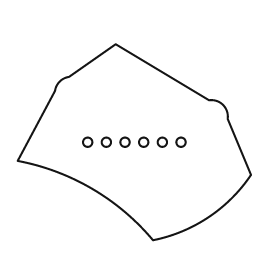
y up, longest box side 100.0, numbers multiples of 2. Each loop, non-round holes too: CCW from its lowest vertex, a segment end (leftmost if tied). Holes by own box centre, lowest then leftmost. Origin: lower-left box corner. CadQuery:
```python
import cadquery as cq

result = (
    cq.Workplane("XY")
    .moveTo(58.0, 0.0)
    .threePointArc((82.0, 10.0), (100.0, 28.0))
    .lineTo(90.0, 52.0)
    .threePointArc((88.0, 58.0), (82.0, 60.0))
    .lineTo(42.0, 84.0)
    .lineTo(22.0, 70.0)
    .threePointArc((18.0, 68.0), (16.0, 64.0))
    .lineTo(0.0, 34.0)
    .threePointArc((32.0, 22.0), (58.0, 0.0))
    .close()
    .moveTo(30.0, 42.0)
    .circle(2.0)
    .moveTo(38.0, 42.0)
    .circle(2.0)
    .moveTo(46.0, 42.0)
    .circle(2.0)
    .moveTo(54.0, 42.0)
    .circle(2.0)
    .moveTo(62.0, 42.0)
    .circle(2.0)
    .moveTo(70.0, 42.0)
    .circle(2.0)
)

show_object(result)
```